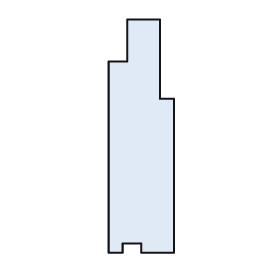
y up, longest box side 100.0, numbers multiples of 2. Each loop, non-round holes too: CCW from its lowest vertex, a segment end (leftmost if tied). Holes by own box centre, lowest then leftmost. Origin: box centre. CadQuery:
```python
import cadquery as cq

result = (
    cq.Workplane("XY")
    .moveTo(-14.0, -50.0)
    .lineTo(-8.0, -50.0)
    .lineTo(-8.0, -46.0)
    .lineTo(0.0, -46.0)
    .lineTo(0.0, -50.0)
    .lineTo(14.0, -50.0)
    .lineTo(14.0, 16.0)
    .lineTo(8.0, 16.0)
    .lineTo(8.0, 50.0)
    .lineTo(-6.0, 50.0)
    .lineTo(-6.0, 32.0)
    .lineTo(-14.0, 32.0)
    .close()
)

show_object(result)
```